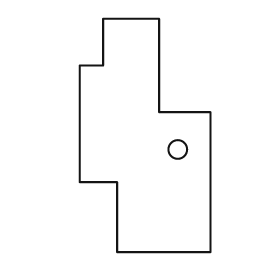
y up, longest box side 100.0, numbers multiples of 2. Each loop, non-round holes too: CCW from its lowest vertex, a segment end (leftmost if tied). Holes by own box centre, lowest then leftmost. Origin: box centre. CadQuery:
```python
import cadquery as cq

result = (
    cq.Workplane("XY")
    .moveTo(-12.0, -50.0)
    .lineTo(28.0, -50.0)
    .lineTo(28.0, 10.0)
    .lineTo(6.0, 10.0)
    .lineTo(6.0, 50.0)
    .lineTo(-18.0, 50.0)
    .lineTo(-18.0, 30.0)
    .lineTo(-28.0, 30.0)
    .lineTo(-28.0, -20.0)
    .lineTo(-12.0, -20.0)
    .close()
    .moveTo(14.0, -6.0)
    .circle(4.0)
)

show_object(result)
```